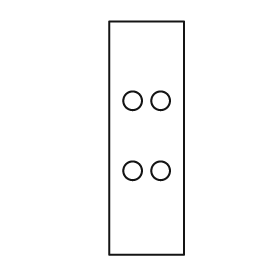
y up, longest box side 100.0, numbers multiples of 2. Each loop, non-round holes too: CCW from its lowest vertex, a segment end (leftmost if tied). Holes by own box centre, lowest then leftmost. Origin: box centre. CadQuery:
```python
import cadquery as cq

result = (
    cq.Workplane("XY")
    .moveTo(-16.0, -50.0)
    .lineTo(16.0, -50.0)
    .lineTo(16.0, 50.0)
    .lineTo(-16.0, 50.0)
    .close()
    .moveTo(-6.0, -14.0)
    .circle(4.0)
    .moveTo(6.0, -14.0)
    .circle(4.0)
    .moveTo(-6.0, 16.0)
    .circle(4.0)
    .moveTo(6.0, 16.0)
    .circle(4.0)
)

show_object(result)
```